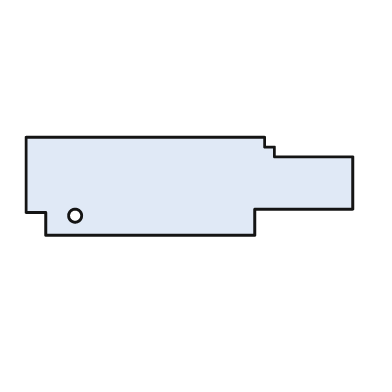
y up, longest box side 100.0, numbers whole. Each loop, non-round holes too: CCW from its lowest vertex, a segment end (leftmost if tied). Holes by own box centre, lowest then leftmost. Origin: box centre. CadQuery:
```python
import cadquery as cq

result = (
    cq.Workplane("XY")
    .moveTo(-44.0, -15.0)
    .lineTo(20.0, -15.0)
    .lineTo(20.0, -7.0)
    .lineTo(50.0, -7.0)
    .lineTo(50.0, 9.0)
    .lineTo(26.0, 9.0)
    .lineTo(26.0, 12.0)
    .lineTo(23.0, 12.0)
    .lineTo(23.0, 15.0)
    .lineTo(-50.0, 15.0)
    .lineTo(-50.0, -8.0)
    .lineTo(-44.0, -8.0)
    .close()
    .moveTo(-35.0, -9.0)
    .circle(2.0)
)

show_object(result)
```